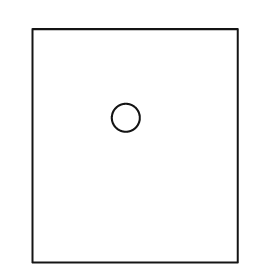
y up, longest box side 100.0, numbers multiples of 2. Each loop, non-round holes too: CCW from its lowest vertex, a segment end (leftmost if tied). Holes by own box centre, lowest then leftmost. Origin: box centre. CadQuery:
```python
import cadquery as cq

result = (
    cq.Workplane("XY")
    .moveTo(-44.0, -50.0)
    .lineTo(44.0, -50.0)
    .lineTo(44.0, 50.0)
    .lineTo(-44.0, 50.0)
    .close()
    .moveTo(-4.0, 12.0)
    .circle(6.0)
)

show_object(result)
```